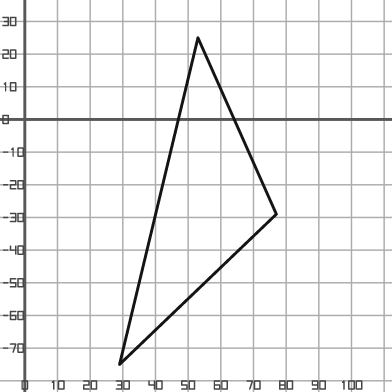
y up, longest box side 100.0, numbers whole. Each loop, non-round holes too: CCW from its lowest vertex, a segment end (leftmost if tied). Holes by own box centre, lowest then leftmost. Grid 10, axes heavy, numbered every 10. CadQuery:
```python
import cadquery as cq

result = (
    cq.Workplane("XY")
    .moveTo(29.0, -75.0)
    .lineTo(77.0, -29.0)
    .lineTo(53.0, 25.0)
    .close()
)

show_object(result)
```